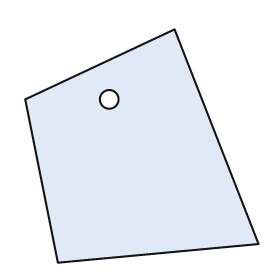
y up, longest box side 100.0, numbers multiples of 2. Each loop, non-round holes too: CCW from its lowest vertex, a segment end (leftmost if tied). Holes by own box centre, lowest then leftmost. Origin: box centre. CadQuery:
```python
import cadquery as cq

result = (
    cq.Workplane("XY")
    .moveTo(-36.0, -50.0)
    .lineTo(50.0, -42.0)
    .lineTo(14.0, 50.0)
    .lineTo(-50.0, 20.0)
    .close()
    .moveTo(-14.0, 20.0)
    .circle(4.0)
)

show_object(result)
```